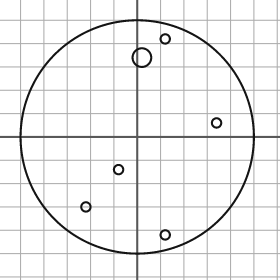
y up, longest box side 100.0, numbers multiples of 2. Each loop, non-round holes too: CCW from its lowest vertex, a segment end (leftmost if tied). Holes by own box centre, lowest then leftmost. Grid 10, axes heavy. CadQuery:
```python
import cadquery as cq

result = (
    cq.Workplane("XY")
    .moveTo(0.0, 0.0)
    .circle(50.0)
    .moveTo(12.0, -42.0)
    .circle(2.0)
    .moveTo(-22.0, -30.0)
    .circle(2.0)
    .moveTo(-8.0, -14.0)
    .circle(2.0)
    .moveTo(34.0, 6.0)
    .circle(2.0)
    .moveTo(2.0, 34.0)
    .circle(4.0)
    .moveTo(12.0, 42.0)
    .circle(2.0)
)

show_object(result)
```